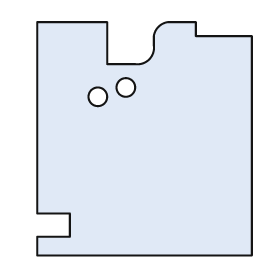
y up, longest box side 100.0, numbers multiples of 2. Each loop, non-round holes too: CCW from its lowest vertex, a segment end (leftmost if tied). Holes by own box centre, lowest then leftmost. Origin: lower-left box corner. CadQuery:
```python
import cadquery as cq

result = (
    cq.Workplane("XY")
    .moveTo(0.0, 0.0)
    .lineTo(92.0, 0.0)
    .lineTo(92.0, 94.0)
    .lineTo(68.0, 94.0)
    .lineTo(68.0, 100.0)
    .lineTo(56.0, 100.0)
    .threePointArc((52.0, 98.0), (50.0, 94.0))
    .lineTo(50.0, 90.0)
    .threePointArc((48.0, 84.0), (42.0, 82.0))
    .lineTo(30.0, 82.0)
    .lineTo(30.0, 100.0)
    .lineTo(0.0, 100.0)
    .lineTo(0.0, 18.0)
    .lineTo(14.0, 18.0)
    .lineTo(14.0, 8.0)
    .lineTo(0.0, 8.0)
    .close()
    .moveTo(26.0, 68.0)
    .circle(4.0)
    .moveTo(38.0, 72.0)
    .circle(4.0)
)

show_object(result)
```